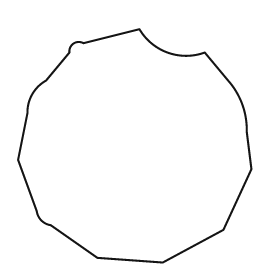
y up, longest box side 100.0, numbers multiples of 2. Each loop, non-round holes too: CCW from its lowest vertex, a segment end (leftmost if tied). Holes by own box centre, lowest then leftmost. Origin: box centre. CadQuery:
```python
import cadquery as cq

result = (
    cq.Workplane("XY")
    .moveTo(12.0, -50.0)
    .lineTo(38.0, -36.0)
    .lineTo(50.0, -10.0)
    .lineTo(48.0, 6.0)
    .threePointArc((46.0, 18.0), (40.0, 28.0))
    .lineTo(30.0, 40.0)
    .threePointArc((14.0, 40.0), (2.0, 50.0))
    .lineTo(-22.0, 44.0)
    .threePointArc((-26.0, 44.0), (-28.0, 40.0))
    .lineTo(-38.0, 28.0)
    .threePointArc((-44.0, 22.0), (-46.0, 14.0))
    .lineTo(-50.0, -6.0)
    .lineTo(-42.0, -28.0)
    .threePointArc((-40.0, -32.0), (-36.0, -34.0))
    .lineTo(-16.0, -48.0)
    .close()
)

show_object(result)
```